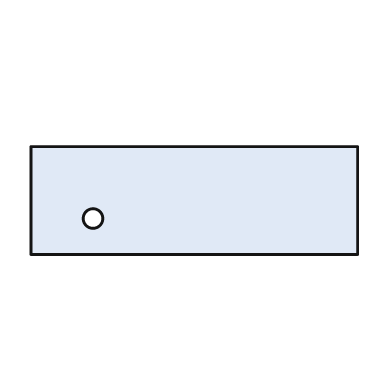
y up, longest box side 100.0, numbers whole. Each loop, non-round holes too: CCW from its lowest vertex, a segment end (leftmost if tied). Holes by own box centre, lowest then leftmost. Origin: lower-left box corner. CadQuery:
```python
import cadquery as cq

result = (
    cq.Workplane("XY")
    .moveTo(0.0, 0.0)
    .lineTo(100.0, 0.0)
    .lineTo(100.0, 33.0)
    .lineTo(0.0, 33.0)
    .close()
    .moveTo(19.0, 11.0)
    .circle(3.0)
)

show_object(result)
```